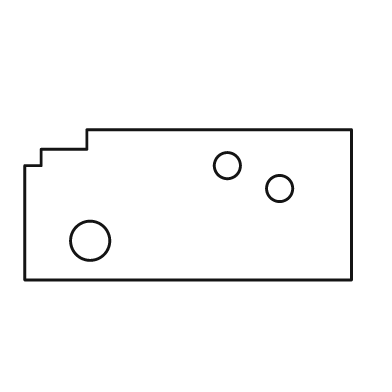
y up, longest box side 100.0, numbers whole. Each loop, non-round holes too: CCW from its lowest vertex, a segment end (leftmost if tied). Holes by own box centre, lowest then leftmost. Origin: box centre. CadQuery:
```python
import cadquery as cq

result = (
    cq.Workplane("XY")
    .moveTo(-50.0, -23.0)
    .lineTo(50.0, -23.0)
    .lineTo(50.0, 23.0)
    .lineTo(-31.0, 23.0)
    .lineTo(-31.0, 17.0)
    .lineTo(-45.0, 17.0)
    .lineTo(-45.0, 12.0)
    .lineTo(-50.0, 12.0)
    .close()
    .moveTo(-30.0, -11.0)
    .circle(6.0)
    .moveTo(28.0, 5.0)
    .circle(4.0)
    .moveTo(12.0, 12.0)
    .circle(4.0)
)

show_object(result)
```